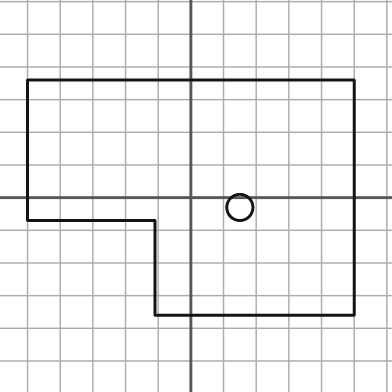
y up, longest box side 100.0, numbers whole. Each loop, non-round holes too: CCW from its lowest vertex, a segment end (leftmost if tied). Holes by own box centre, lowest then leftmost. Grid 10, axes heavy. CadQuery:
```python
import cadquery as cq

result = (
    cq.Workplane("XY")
    .moveTo(-11.0, -36.0)
    .lineTo(50.0, -36.0)
    .lineTo(50.0, 36.0)
    .lineTo(-50.0, 36.0)
    .lineTo(-50.0, -7.0)
    .lineTo(-11.0, -7.0)
    .close()
    .moveTo(15.0, -3.0)
    .circle(4.0)
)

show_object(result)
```